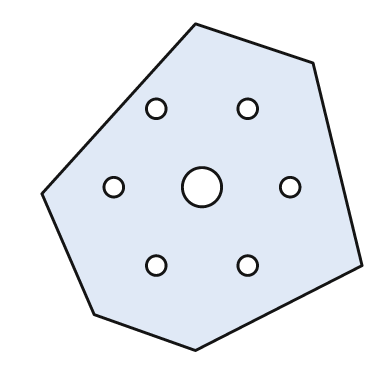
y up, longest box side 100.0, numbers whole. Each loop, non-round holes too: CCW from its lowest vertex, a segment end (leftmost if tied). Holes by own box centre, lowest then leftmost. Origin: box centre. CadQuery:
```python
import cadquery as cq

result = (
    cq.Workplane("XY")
    .moveTo(-2.0, -50.0)
    .lineTo(49.0, -24.0)
    .lineTo(34.0, 38.0)
    .lineTo(-2.0, 50.0)
    .lineTo(-49.0, -2.0)
    .lineTo(-33.0, -39.0)
    .close()
    .moveTo(-14.0, -24.0)
    .circle(3.0)
    .moveTo(14.0, -24.0)
    .circle(3.0)
    .moveTo(-27.0, 0.0)
    .circle(3.0)
    .moveTo(0.0, 0.0)
    .circle(6.0)
    .moveTo(27.0, 0.0)
    .circle(3.0)
    .moveTo(-14.0, 24.0)
    .circle(3.0)
    .moveTo(14.0, 24.0)
    .circle(3.0)
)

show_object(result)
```